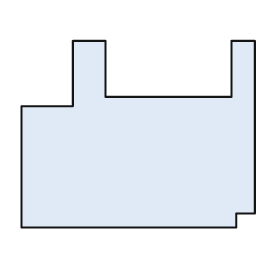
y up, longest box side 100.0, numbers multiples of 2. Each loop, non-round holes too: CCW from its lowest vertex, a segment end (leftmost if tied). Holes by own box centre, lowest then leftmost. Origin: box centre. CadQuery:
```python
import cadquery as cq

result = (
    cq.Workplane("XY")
    .moveTo(-50.0, -40.0)
    .lineTo(42.0, -40.0)
    .lineTo(42.0, -34.0)
    .lineTo(50.0, -34.0)
    .lineTo(50.0, 40.0)
    .lineTo(40.0, 40.0)
    .lineTo(40.0, 16.0)
    .lineTo(-14.0, 16.0)
    .lineTo(-14.0, 40.0)
    .lineTo(-28.0, 40.0)
    .lineTo(-28.0, 12.0)
    .lineTo(-50.0, 12.0)
    .close()
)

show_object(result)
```